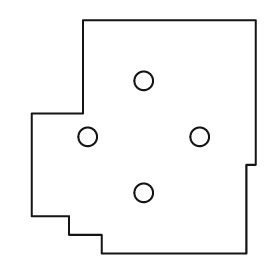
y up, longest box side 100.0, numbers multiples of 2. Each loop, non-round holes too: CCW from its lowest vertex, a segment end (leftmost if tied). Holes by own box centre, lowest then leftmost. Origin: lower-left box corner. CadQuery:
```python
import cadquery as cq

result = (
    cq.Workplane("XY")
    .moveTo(30.0, 0.0)
    .lineTo(92.0, 0.0)
    .lineTo(92.0, 38.0)
    .lineTo(96.0, 38.0)
    .lineTo(96.0, 100.0)
    .lineTo(22.0, 100.0)
    .lineTo(22.0, 60.0)
    .lineTo(0.0, 60.0)
    .lineTo(0.0, 16.0)
    .lineTo(16.0, 16.0)
    .lineTo(16.0, 8.0)
    .lineTo(30.0, 8.0)
    .close()
    .moveTo(48.0, 26.0)
    .circle(4.0)
    .moveTo(24.0, 50.0)
    .circle(4.0)
    .moveTo(72.0, 50.0)
    .circle(4.0)
    .moveTo(48.0, 74.0)
    .circle(4.0)
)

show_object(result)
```